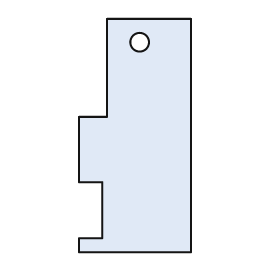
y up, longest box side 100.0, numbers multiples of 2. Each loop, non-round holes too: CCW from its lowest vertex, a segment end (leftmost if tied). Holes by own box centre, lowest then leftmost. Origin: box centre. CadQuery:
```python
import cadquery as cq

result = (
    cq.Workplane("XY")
    .moveTo(-24.0, -50.0)
    .lineTo(24.0, -50.0)
    .lineTo(24.0, 50.0)
    .lineTo(-12.0, 50.0)
    .lineTo(-12.0, 8.0)
    .lineTo(-24.0, 8.0)
    .lineTo(-24.0, -20.0)
    .lineTo(-14.0, -20.0)
    .lineTo(-14.0, -44.0)
    .lineTo(-24.0, -44.0)
    .close()
    .moveTo(2.0, 40.0)
    .circle(4.0)
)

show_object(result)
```